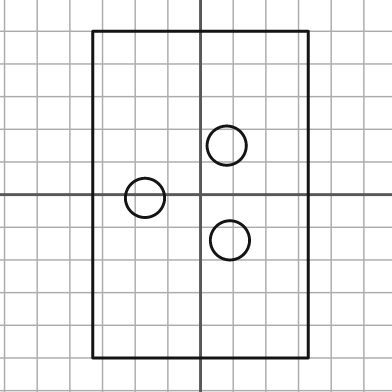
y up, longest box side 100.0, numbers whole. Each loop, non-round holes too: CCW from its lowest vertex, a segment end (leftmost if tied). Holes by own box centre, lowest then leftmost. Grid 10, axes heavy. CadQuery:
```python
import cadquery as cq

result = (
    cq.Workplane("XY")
    .moveTo(-33.0, -50.0)
    .lineTo(33.0, -50.0)
    .lineTo(33.0, 50.0)
    .lineTo(-33.0, 50.0)
    .close()
    .moveTo(9.0, -14.0)
    .circle(6.0)
    .moveTo(-17.0, -1.0)
    .circle(6.0)
    .moveTo(8.0, 15.0)
    .circle(6.0)
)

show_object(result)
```